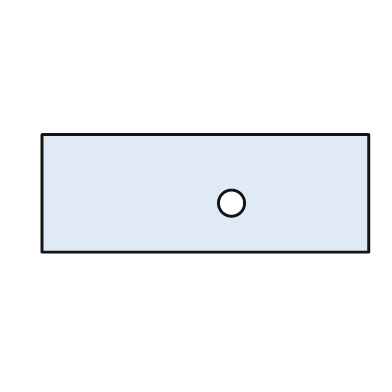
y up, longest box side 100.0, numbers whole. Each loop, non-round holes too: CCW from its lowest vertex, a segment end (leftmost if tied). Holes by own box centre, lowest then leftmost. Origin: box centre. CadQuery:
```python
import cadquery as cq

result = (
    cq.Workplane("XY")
    .moveTo(-50.0, -18.0)
    .lineTo(50.0, -18.0)
    .lineTo(50.0, 18.0)
    .lineTo(-50.0, 18.0)
    .close()
    .moveTo(8.0, -3.0)
    .circle(4.0)
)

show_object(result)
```